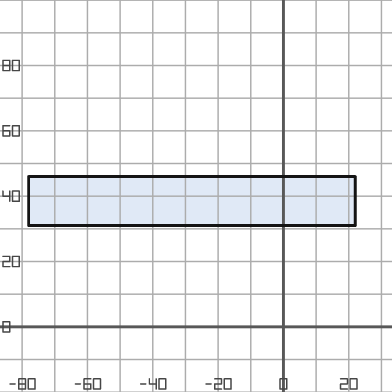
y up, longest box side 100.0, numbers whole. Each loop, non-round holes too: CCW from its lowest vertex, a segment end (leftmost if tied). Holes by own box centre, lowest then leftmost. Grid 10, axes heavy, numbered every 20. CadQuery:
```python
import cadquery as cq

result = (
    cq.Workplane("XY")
    .moveTo(-78.0, 31.0)
    .lineTo(22.0, 31.0)
    .lineTo(22.0, 46.0)
    .lineTo(-78.0, 46.0)
    .close()
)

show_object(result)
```